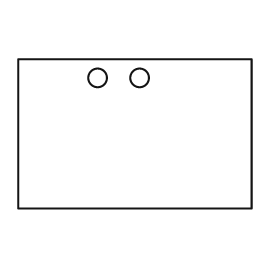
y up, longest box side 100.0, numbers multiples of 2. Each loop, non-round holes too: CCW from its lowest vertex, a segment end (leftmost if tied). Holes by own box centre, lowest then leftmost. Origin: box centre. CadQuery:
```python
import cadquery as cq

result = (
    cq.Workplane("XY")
    .moveTo(-50.0, -32.0)
    .lineTo(50.0, -32.0)
    .lineTo(50.0, 32.0)
    .lineTo(-50.0, 32.0)
    .close()
    .moveTo(-16.0, 24.0)
    .circle(4.0)
    .moveTo(2.0, 24.0)
    .circle(4.0)
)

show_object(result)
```